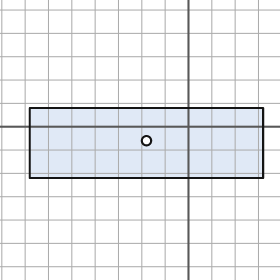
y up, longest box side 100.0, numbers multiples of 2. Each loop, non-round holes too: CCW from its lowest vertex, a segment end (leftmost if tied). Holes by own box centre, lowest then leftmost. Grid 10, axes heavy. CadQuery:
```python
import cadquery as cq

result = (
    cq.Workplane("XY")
    .moveTo(-68.0, -22.0)
    .lineTo(32.0, -22.0)
    .lineTo(32.0, 8.0)
    .lineTo(-68.0, 8.0)
    .close()
    .moveTo(-18.0, -6.0)
    .circle(2.0)
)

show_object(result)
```